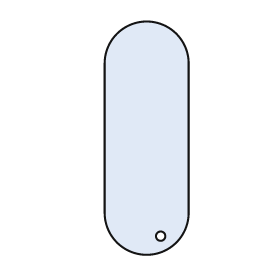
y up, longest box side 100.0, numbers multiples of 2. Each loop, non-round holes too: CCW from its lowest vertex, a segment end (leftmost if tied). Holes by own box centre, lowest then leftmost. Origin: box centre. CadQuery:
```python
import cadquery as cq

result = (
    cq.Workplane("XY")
    .moveTo(-18.0, -32.0)
    .threePointArc((0.0, -50.0), (18.0, -32.0))
    .lineTo(18.0, 32.0)
    .threePointArc((0.0, 50.0), (-18.0, 32.0))
    .close()
    .moveTo(6.0, -42.0)
    .circle(2.0)
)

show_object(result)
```